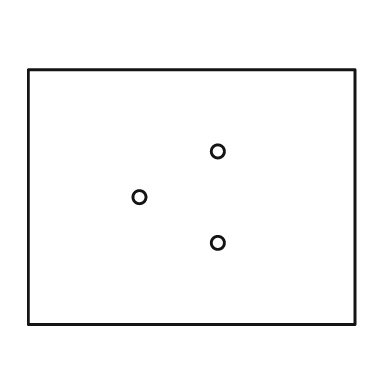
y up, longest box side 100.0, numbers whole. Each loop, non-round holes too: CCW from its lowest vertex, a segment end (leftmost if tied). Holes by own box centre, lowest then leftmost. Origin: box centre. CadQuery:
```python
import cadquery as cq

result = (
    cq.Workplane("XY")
    .moveTo(-50.0, -39.0)
    .lineTo(50.0, -39.0)
    .lineTo(50.0, 39.0)
    .lineTo(-50.0, 39.0)
    .close()
    .moveTo(8.0, -14.0)
    .circle(2.0)
    .moveTo(-16.0, 0.0)
    .circle(2.0)
    .moveTo(8.0, 14.0)
    .circle(2.0)
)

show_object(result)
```